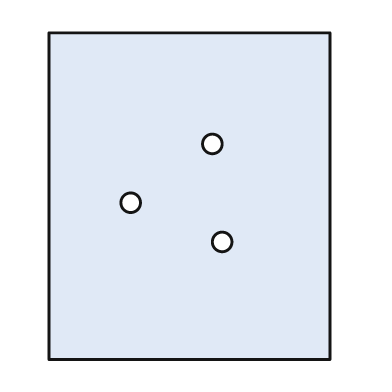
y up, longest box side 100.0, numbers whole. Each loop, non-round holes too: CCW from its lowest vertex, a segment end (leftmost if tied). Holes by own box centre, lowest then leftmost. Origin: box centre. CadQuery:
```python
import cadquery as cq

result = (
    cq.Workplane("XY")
    .moveTo(-43.0, -50.0)
    .lineTo(43.0, -50.0)
    .lineTo(43.0, 50.0)
    .lineTo(-43.0, 50.0)
    .close()
    .moveTo(10.0, -14.0)
    .circle(3.0)
    .moveTo(-18.0, -2.0)
    .circle(3.0)
    .moveTo(7.0, 16.0)
    .circle(3.0)
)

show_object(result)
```